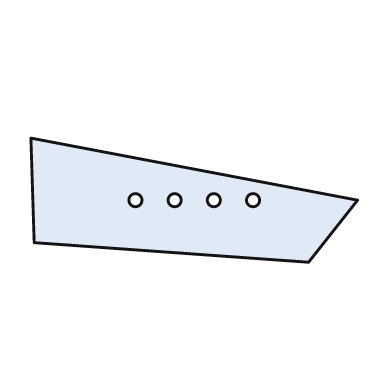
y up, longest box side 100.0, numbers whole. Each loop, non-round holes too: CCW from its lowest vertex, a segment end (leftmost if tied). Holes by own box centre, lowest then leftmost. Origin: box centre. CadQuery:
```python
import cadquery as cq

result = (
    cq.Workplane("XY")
    .moveTo(35.0, -19.0)
    .lineTo(50.0, 0.0)
    .lineTo(-50.0, 19.0)
    .lineTo(-49.0, -13.0)
    .close()
    .moveTo(-18.0, 0.0)
    .circle(2.0)
    .moveTo(-6.0, 0.0)
    .circle(2.0)
    .moveTo(6.0, 0.0)
    .circle(2.0)
    .moveTo(18.0, 0.0)
    .circle(2.0)
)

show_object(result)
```